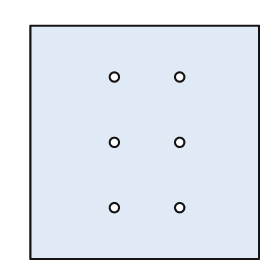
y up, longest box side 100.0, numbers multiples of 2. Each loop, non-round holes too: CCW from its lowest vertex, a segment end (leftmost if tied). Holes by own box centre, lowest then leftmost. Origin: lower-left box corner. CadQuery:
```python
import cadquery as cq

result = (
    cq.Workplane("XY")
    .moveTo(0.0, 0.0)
    .lineTo(98.0, 0.0)
    .lineTo(98.0, 100.0)
    .lineTo(0.0, 100.0)
    .close()
    .moveTo(36.0, 22.0)
    .circle(2.0)
    .moveTo(64.0, 22.0)
    .circle(2.0)
    .moveTo(36.0, 50.0)
    .circle(2.0)
    .moveTo(64.0, 50.0)
    .circle(2.0)
    .moveTo(36.0, 78.0)
    .circle(2.0)
    .moveTo(64.0, 78.0)
    .circle(2.0)
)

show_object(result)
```